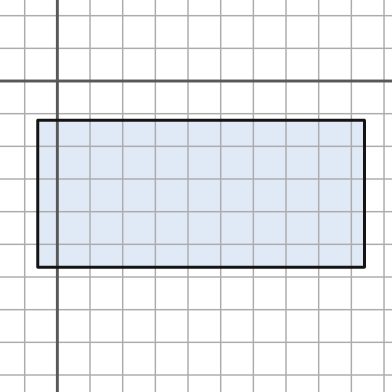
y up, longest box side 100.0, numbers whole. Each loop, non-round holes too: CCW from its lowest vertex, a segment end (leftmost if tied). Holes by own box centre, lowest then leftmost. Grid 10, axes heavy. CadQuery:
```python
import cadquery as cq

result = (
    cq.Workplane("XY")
    .moveTo(-6.0, -57.0)
    .lineTo(94.0, -57.0)
    .lineTo(94.0, -12.0)
    .lineTo(-6.0, -12.0)
    .close()
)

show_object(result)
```